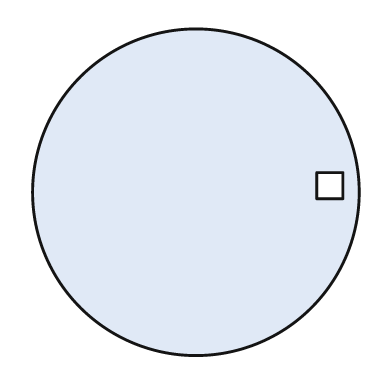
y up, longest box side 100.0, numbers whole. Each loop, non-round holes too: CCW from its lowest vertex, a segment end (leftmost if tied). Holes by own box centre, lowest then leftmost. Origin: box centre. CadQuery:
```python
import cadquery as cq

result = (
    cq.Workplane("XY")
    .moveTo(0.0, 0.0)
    .circle(50.0)
    .moveTo(37.0, -2.0)
    .lineTo(45.0, -2.0)
    .lineTo(45.0, 6.0)
    .lineTo(37.0, 6.0)
    .close()
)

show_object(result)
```